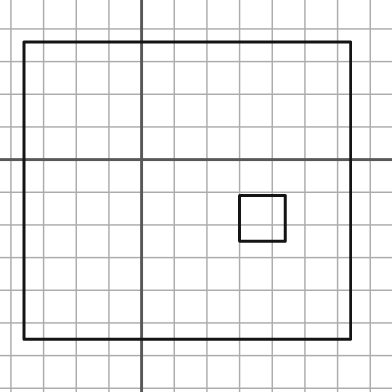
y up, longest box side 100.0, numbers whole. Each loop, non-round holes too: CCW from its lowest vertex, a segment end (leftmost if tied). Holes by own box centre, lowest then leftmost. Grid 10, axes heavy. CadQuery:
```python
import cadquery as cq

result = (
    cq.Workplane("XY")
    .moveTo(-36.0, -55.0)
    .lineTo(64.0, -55.0)
    .lineTo(64.0, 36.0)
    .lineTo(-36.0, 36.0)
    .close()
    .moveTo(30.0, -25.0)
    .lineTo(44.0, -25.0)
    .lineTo(44.0, -11.0)
    .lineTo(30.0, -11.0)
    .close()
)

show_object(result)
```